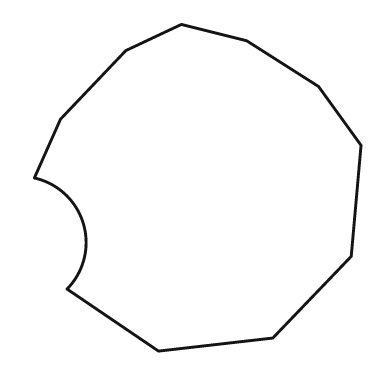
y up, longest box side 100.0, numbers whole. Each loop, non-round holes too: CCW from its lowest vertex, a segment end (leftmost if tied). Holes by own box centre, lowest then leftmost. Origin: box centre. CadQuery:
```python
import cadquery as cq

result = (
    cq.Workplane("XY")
    .moveTo(-12.0, -50.0)
    .lineTo(23.0, -46.0)
    .lineTo(47.0, -21.0)
    .lineTo(50.0, 13.0)
    .lineTo(37.0, 31.0)
    .lineTo(15.0, 45.0)
    .lineTo(-5.0, 50.0)
    .lineTo(-22.0, 42.0)
    .lineTo(-42.0, 21.0)
    .lineTo(-50.0, 3.0)
    .threePointArc((-35.0, -11.0), (-40.0, -31.0))
    .close()
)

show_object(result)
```